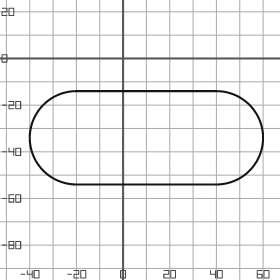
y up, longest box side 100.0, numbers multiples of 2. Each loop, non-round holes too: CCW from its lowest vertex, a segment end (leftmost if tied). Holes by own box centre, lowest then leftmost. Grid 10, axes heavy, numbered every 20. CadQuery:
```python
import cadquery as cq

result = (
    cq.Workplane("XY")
    .moveTo(-20.0, -54.0)
    .lineTo(40.0, -54.0)
    .threePointArc((60.0, -34.0), (40.0, -14.0))
    .lineTo(-20.0, -14.0)
    .threePointArc((-40.0, -34.0), (-20.0, -54.0))
    .close()
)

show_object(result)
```